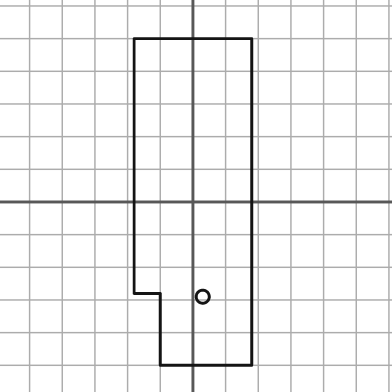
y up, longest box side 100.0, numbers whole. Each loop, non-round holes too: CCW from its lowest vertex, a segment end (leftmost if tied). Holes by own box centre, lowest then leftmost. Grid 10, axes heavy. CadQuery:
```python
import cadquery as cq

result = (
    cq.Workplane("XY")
    .moveTo(-10.0, -50.0)
    .lineTo(18.0, -50.0)
    .lineTo(18.0, 50.0)
    .lineTo(-18.0, 50.0)
    .lineTo(-18.0, -28.0)
    .lineTo(-10.0, -28.0)
    .close()
    .moveTo(3.0, -29.0)
    .circle(2.0)
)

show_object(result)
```